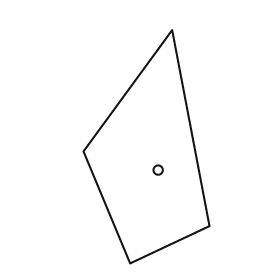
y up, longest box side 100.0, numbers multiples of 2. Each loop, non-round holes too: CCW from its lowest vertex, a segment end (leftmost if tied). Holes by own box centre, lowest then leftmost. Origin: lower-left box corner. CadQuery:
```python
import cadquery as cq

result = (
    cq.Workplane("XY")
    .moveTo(20.0, 0.0)
    .lineTo(54.0, 16.0)
    .lineTo(38.0, 100.0)
    .lineTo(0.0, 48.0)
    .close()
    .moveTo(32.0, 40.0)
    .circle(2.0)
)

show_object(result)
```